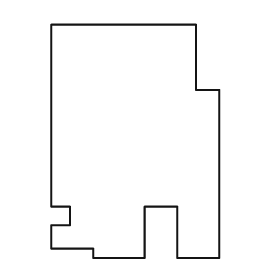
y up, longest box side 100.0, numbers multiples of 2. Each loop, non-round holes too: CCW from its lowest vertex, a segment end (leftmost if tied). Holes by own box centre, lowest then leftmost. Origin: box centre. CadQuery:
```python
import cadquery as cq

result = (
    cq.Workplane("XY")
    .moveTo(-18.0, -50.0)
    .lineTo(4.0, -50.0)
    .lineTo(4.0, -28.0)
    .lineTo(18.0, -28.0)
    .lineTo(18.0, -50.0)
    .lineTo(36.0, -50.0)
    .lineTo(36.0, 22.0)
    .lineTo(26.0, 22.0)
    .lineTo(26.0, 50.0)
    .lineTo(-36.0, 50.0)
    .lineTo(-36.0, -28.0)
    .lineTo(-28.0, -28.0)
    .lineTo(-28.0, -36.0)
    .lineTo(-36.0, -36.0)
    .lineTo(-36.0, -46.0)
    .lineTo(-18.0, -46.0)
    .close()
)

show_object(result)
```